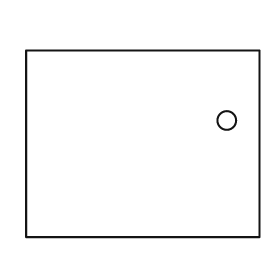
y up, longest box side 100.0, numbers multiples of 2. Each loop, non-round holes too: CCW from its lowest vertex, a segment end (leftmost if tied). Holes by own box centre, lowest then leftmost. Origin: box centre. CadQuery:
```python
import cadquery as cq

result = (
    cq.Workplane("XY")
    .moveTo(-50.0, -40.0)
    .lineTo(50.0, -40.0)
    .lineTo(50.0, 40.0)
    .lineTo(-50.0, 40.0)
    .close()
    .moveTo(36.0, 10.0)
    .circle(4.0)
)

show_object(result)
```